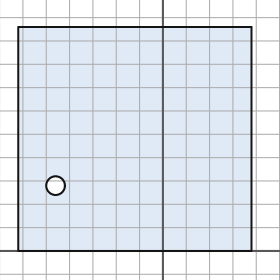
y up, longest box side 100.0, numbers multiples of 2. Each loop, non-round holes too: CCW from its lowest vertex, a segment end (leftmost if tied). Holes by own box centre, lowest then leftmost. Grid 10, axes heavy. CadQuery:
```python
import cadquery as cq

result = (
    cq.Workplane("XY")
    .moveTo(-62.0, 0.0)
    .lineTo(38.0, 0.0)
    .lineTo(38.0, 96.0)
    .lineTo(-62.0, 96.0)
    .close()
    .moveTo(-46.0, 28.0)
    .circle(4.0)
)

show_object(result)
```